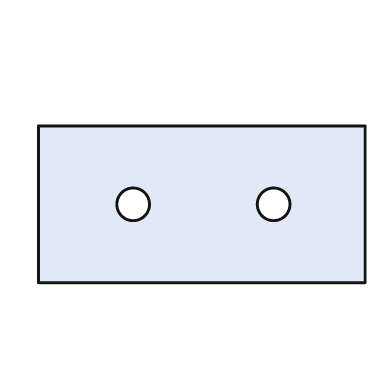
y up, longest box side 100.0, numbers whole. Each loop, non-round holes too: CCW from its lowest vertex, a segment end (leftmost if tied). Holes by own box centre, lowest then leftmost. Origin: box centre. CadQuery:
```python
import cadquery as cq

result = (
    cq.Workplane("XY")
    .moveTo(-50.0, -24.0)
    .lineTo(50.0, -24.0)
    .lineTo(50.0, 24.0)
    .lineTo(-50.0, 24.0)
    .close()
    .moveTo(-21.0, 0.0)
    .circle(5.0)
    .moveTo(22.0, 0.0)
    .circle(5.0)
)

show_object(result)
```